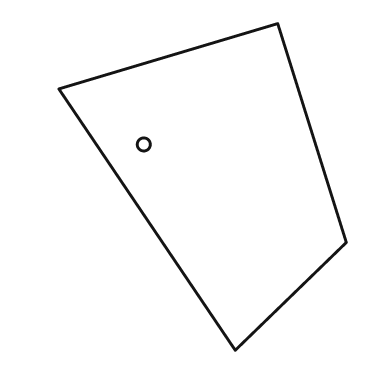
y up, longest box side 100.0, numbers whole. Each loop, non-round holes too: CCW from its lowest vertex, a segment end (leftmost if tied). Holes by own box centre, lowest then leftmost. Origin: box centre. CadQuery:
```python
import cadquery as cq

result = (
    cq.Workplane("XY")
    .moveTo(10.0, -50.0)
    .lineTo(44.0, -17.0)
    .lineTo(23.0, 50.0)
    .lineTo(-44.0, 30.0)
    .close()
    .moveTo(-18.0, 13.0)
    .circle(2.0)
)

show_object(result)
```